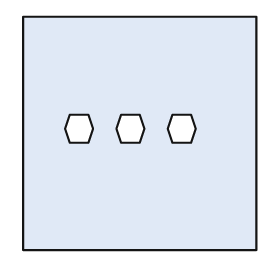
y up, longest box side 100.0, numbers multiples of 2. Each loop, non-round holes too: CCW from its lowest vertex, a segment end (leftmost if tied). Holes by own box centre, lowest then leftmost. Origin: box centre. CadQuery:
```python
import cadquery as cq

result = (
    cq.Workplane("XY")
    .moveTo(-50.0, -50.0)
    .lineTo(50.0, -50.0)
    .lineTo(50.0, 50.0)
    .lineTo(-50.0, 50.0)
    .close()
    .moveTo(-30.0, -4.0)
    .lineTo(-22.0, -4.0)
    .lineTo(-20.0, 2.0)
    .lineTo(-22.0, 8.0)
    .lineTo(-30.0, 8.0)
    .lineTo(-32.0, 2.0)
    .close()
    .moveTo(-8.0, -4.0)
    .lineTo(0.0, -4.0)
    .lineTo(2.0, 2.0)
    .lineTo(0.0, 8.0)
    .lineTo(-8.0, 8.0)
    .lineTo(-10.0, 2.0)
    .close()
    .moveTo(14.0, -4.0)
    .lineTo(22.0, -4.0)
    .lineTo(24.0, 2.0)
    .lineTo(22.0, 8.0)
    .lineTo(14.0, 8.0)
    .lineTo(12.0, 2.0)
    .close()
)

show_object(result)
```